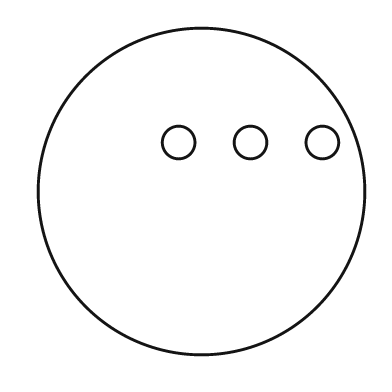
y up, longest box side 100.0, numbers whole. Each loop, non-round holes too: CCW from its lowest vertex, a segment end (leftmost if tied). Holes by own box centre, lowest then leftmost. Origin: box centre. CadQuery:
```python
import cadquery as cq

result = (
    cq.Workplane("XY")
    .moveTo(0.0, 0.0)
    .circle(50.0)
    .moveTo(-7.0, 15.0)
    .circle(5.0)
    .moveTo(15.0, 15.0)
    .circle(5.0)
    .moveTo(37.0, 15.0)
    .circle(5.0)
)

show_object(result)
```